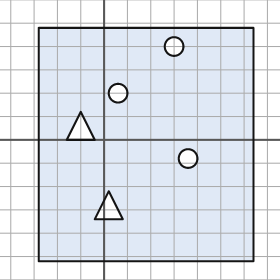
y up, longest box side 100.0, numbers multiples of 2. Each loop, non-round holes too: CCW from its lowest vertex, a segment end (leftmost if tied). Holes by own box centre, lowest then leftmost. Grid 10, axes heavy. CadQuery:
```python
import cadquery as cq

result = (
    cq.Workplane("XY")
    .moveTo(-28.0, -52.0)
    .lineTo(64.0, -52.0)
    .lineTo(64.0, 48.0)
    .lineTo(-28.0, 48.0)
    .close()
    .moveTo(-4.0, -34.0)
    .lineTo(8.0, -34.0)
    .lineTo(2.0, -22.0)
    .close()
    .moveTo(36.0, -8.0)
    .circle(4.0)
    .moveTo(-16.0, 0.0)
    .lineTo(-4.0, 0.0)
    .lineTo(-10.0, 12.0)
    .close()
    .moveTo(6.0, 20.0)
    .circle(4.0)
    .moveTo(30.0, 40.0)
    .circle(4.0)
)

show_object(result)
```